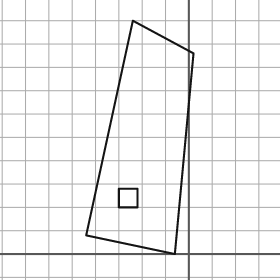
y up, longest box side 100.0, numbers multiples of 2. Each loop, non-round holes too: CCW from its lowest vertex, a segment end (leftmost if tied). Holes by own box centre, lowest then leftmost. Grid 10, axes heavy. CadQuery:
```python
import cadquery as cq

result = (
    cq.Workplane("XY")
    .moveTo(-6.0, 0.0)
    .lineTo(2.0, 86.0)
    .lineTo(-24.0, 100.0)
    .lineTo(-44.0, 8.0)
    .close()
    .moveTo(-30.0, 20.0)
    .lineTo(-22.0, 20.0)
    .lineTo(-22.0, 28.0)
    .lineTo(-30.0, 28.0)
    .close()
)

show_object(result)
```